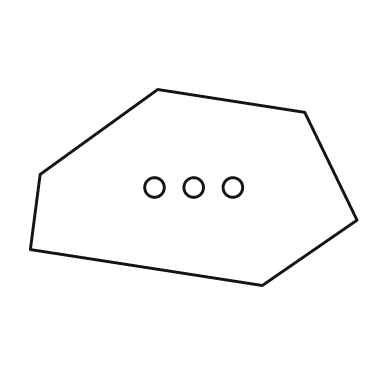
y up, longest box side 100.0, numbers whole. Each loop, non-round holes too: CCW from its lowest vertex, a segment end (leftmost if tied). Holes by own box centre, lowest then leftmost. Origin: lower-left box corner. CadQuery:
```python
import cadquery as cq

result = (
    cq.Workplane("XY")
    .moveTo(71.0, 0.0)
    .lineTo(100.0, 20.0)
    .lineTo(84.0, 53.0)
    .lineTo(39.0, 60.0)
    .lineTo(3.0, 34.0)
    .lineTo(0.0, 11.0)
    .close()
    .moveTo(38.0, 30.0)
    .circle(3.0)
    .moveTo(50.0, 30.0)
    .circle(3.0)
    .moveTo(62.0, 30.0)
    .circle(3.0)
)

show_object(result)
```